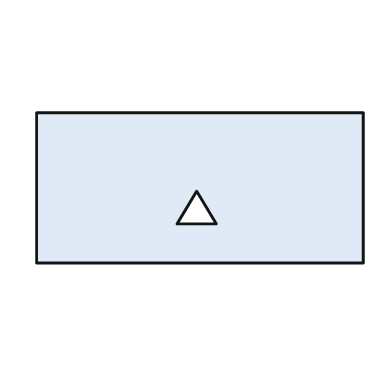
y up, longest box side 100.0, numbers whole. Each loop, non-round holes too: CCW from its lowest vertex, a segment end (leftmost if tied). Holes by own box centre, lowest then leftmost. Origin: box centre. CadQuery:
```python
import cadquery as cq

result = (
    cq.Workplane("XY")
    .moveTo(-50.0, -23.0)
    .lineTo(50.0, -23.0)
    .lineTo(50.0, 23.0)
    .lineTo(-50.0, 23.0)
    .close()
    .moveTo(-7.0, -11.0)
    .lineTo(5.0, -11.0)
    .lineTo(-1.0, -1.0)
    .close()
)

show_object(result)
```